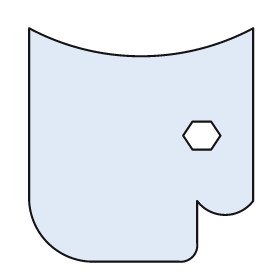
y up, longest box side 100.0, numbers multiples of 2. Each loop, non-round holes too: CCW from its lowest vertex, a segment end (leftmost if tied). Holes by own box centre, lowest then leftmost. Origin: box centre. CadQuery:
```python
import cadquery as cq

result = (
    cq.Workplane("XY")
    .moveTo(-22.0, -50.0)
    .lineTo(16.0, -50.0)
    .threePointArc((22.0, -48.0), (24.0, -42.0))
    .lineTo(24.0, -24.0)
    .threePointArc((36.0, -30.0), (48.0, -24.0))
    .lineTo(48.0, 50.0)
    .threePointArc((0.0, 38.0), (-48.0, 50.0))
    .lineTo(-48.0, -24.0)
    .threePointArc((-40.0, -42.0), (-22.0, -50.0))
    .close()
    .moveTo(22.0, -2.0)
    .lineTo(30.0, -2.0)
    .lineTo(34.0, 4.0)
    .lineTo(30.0, 10.0)
    .lineTo(22.0, 10.0)
    .lineTo(18.0, 4.0)
    .close()
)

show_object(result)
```